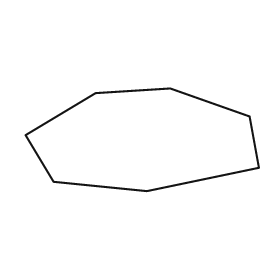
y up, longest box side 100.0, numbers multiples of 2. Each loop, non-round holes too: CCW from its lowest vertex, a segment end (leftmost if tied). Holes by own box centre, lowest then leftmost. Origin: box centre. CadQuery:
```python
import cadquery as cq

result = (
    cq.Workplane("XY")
    .moveTo(2.0, -22.0)
    .lineTo(50.0, -12.0)
    .lineTo(46.0, 10.0)
    .lineTo(12.0, 22.0)
    .lineTo(-20.0, 20.0)
    .lineTo(-50.0, 2.0)
    .lineTo(-38.0, -18.0)
    .close()
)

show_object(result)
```